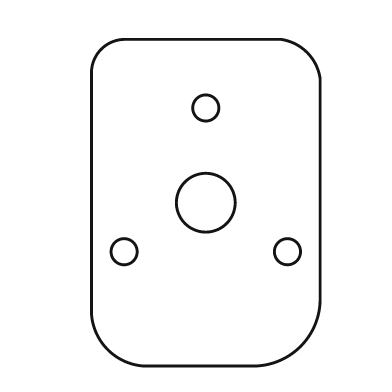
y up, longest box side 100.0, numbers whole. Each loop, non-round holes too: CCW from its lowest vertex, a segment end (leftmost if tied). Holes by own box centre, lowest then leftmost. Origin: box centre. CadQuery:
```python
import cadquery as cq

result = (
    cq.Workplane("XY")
    .moveTo(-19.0, -50.0)
    .lineTo(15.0, -50.0)
    .threePointArc((29.0, -44.0), (35.0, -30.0))
    .lineTo(35.0, 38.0)
    .threePointArc((31.0, 46.0), (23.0, 50.0))
    .lineTo(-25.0, 50.0)
    .threePointArc((-32.0, 47.0), (-35.0, 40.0))
    .lineTo(-35.0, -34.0)
    .threePointArc((-30.0, -45.0), (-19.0, -50.0))
    .close()
    .moveTo(-25.0, -15.0)
    .circle(4.0)
    .moveTo(25.0, -15.0)
    .circle(4.0)
    .moveTo(0.0, 0.0)
    .circle(9.0)
    .moveTo(0.0, 29.0)
    .circle(4.0)
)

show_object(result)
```